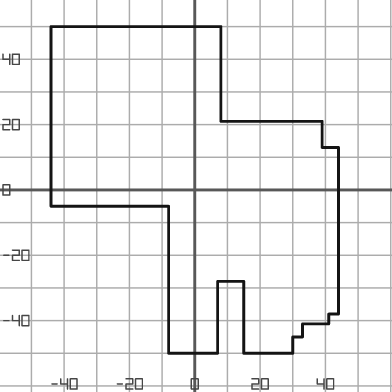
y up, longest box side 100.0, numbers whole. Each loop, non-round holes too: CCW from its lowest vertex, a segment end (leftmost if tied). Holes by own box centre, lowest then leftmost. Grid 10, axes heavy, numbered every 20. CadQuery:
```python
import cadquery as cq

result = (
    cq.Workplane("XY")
    .moveTo(-8.0, -50.0)
    .lineTo(7.0, -50.0)
    .lineTo(7.0, -28.0)
    .lineTo(15.0, -28.0)
    .lineTo(15.0, -50.0)
    .lineTo(30.0, -50.0)
    .lineTo(30.0, -45.0)
    .lineTo(33.0, -45.0)
    .lineTo(33.0, -41.0)
    .lineTo(41.0, -41.0)
    .lineTo(41.0, -38.0)
    .lineTo(44.0, -38.0)
    .lineTo(44.0, 13.0)
    .lineTo(39.0, 13.0)
    .lineTo(39.0, 21.0)
    .lineTo(8.0, 21.0)
    .lineTo(8.0, 50.0)
    .lineTo(-44.0, 50.0)
    .lineTo(-44.0, -5.0)
    .lineTo(-8.0, -5.0)
    .close()
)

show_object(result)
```